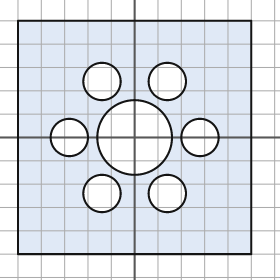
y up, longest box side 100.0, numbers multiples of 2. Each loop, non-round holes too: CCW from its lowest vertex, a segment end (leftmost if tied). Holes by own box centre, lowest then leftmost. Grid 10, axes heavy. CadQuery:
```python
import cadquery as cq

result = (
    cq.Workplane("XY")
    .moveTo(-50.0, -50.0)
    .lineTo(50.0, -50.0)
    .lineTo(50.0, 50.0)
    .lineTo(-50.0, 50.0)
    .close()
    .moveTo(-14.0, -24.0)
    .circle(8.0)
    .moveTo(14.0, -24.0)
    .circle(8.0)
    .moveTo(-28.0, 0.0)
    .circle(8.0)
    .moveTo(0.0, 0.0)
    .circle(16.0)
    .moveTo(28.0, 0.0)
    .circle(8.0)
    .moveTo(-14.0, 24.0)
    .circle(8.0)
    .moveTo(14.0, 24.0)
    .circle(8.0)
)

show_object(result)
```